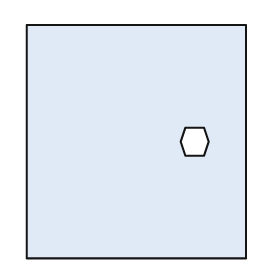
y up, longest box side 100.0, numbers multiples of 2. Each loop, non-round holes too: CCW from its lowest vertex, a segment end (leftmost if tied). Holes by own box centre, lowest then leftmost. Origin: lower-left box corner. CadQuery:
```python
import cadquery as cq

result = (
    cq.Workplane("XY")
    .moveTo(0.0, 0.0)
    .lineTo(94.0, 0.0)
    .lineTo(94.0, 100.0)
    .lineTo(0.0, 100.0)
    .close()
    .moveTo(68.0, 44.0)
    .lineTo(76.0, 44.0)
    .lineTo(78.0, 50.0)
    .lineTo(76.0, 56.0)
    .lineTo(68.0, 56.0)
    .lineTo(66.0, 50.0)
    .close()
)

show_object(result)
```